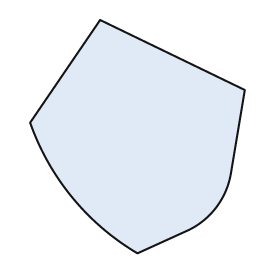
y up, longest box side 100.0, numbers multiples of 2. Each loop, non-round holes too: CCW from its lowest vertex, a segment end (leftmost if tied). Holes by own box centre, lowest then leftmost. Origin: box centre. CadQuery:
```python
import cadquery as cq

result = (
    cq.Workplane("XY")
    .moveTo(0.0, -50.0)
    .lineTo(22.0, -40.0)
    .threePointArc((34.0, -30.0), (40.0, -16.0))
    .lineTo(46.0, 20.0)
    .lineTo(-16.0, 50.0)
    .lineTo(-46.0, 6.0)
    .threePointArc((-28.0, -26.0), (0.0, -50.0))
    .close()
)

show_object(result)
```